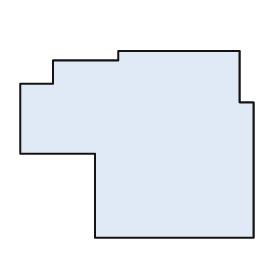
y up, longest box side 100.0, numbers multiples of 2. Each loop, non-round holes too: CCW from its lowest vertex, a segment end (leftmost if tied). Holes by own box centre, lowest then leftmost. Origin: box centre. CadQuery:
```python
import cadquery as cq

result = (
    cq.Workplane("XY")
    .moveTo(-18.0, -40.0)
    .lineTo(50.0, -40.0)
    .lineTo(50.0, 18.0)
    .lineTo(44.0, 18.0)
    .lineTo(44.0, 40.0)
    .lineTo(-8.0, 40.0)
    .lineTo(-8.0, 36.0)
    .lineTo(-36.0, 36.0)
    .lineTo(-36.0, 26.0)
    .lineTo(-50.0, 26.0)
    .lineTo(-50.0, -4.0)
    .lineTo(-18.0, -4.0)
    .close()
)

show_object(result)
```